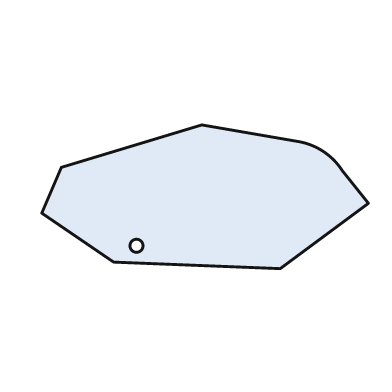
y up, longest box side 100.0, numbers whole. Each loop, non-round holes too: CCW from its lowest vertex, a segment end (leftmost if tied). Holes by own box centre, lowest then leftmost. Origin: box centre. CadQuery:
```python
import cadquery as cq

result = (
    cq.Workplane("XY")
    .moveTo(23.0, -22.0)
    .lineTo(50.0, -2.0)
    .lineTo(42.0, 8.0)
    .threePointArc((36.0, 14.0), (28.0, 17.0))
    .lineTo(-1.0, 22.0)
    .lineTo(-44.0, 9.0)
    .lineTo(-50.0, -5.0)
    .lineTo(-28.0, -20.0)
    .close()
    .moveTo(-21.0, -15.0)
    .circle(2.0)
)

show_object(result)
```